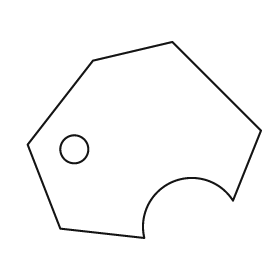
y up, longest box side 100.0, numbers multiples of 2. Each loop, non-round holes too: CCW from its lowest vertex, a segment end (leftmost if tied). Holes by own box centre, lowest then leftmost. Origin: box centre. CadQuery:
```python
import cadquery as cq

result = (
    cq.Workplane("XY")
    .moveTo(0.0, -42.0)
    .threePointArc((12.0, -18.0), (38.0, -26.0))
    .lineTo(50.0, 4.0)
    .lineTo(12.0, 42.0)
    .lineTo(-22.0, 34.0)
    .lineTo(-50.0, -2.0)
    .lineTo(-36.0, -38.0)
    .close()
    .moveTo(-30.0, -4.0)
    .circle(6.0)
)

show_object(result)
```